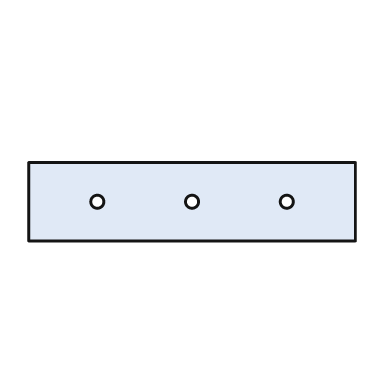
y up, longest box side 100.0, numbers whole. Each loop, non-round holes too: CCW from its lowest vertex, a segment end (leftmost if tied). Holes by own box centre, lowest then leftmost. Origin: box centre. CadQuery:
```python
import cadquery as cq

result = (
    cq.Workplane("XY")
    .moveTo(-50.0, -12.0)
    .lineTo(50.0, -12.0)
    .lineTo(50.0, 12.0)
    .lineTo(-50.0, 12.0)
    .close()
    .moveTo(-29.0, 0.0)
    .circle(2.0)
    .moveTo(0.0, 0.0)
    .circle(2.0)
    .moveTo(29.0, 0.0)
    .circle(2.0)
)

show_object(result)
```